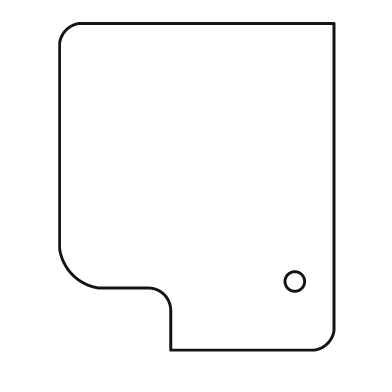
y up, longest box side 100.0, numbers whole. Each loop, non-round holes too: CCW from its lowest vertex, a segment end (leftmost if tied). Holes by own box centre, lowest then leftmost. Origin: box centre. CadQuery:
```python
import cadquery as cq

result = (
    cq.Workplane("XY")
    .moveTo(-8.0, -50.0)
    .lineTo(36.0, -50.0)
    .threePointArc((40.0, -48.0), (42.0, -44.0))
    .lineTo(42.0, 50.0)
    .lineTo(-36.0, 50.0)
    .threePointArc((-40.0, 48.0), (-42.0, 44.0))
    .lineTo(-42.0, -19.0)
    .threePointArc((-38.0, -27.0), (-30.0, -31.0))
    .lineTo(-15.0, -31.0)
    .threePointArc((-10.0, -33.0), (-8.0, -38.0))
    .close()
    .moveTo(30.0, -29.0)
    .circle(3.0)
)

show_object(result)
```